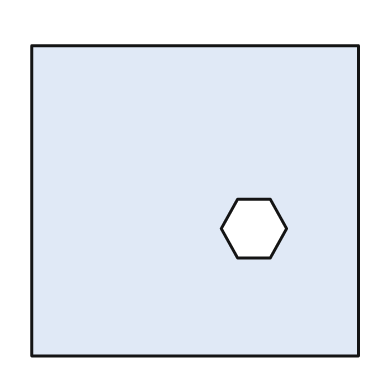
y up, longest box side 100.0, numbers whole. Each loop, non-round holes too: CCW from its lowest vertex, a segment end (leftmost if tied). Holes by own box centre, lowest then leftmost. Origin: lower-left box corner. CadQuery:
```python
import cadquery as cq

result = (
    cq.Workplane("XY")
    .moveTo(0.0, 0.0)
    .lineTo(100.0, 0.0)
    .lineTo(100.0, 95.0)
    .lineTo(0.0, 95.0)
    .close()
    .moveTo(63.0, 30.0)
    .lineTo(73.0, 30.0)
    .lineTo(78.0, 39.0)
    .lineTo(73.0, 48.0)
    .lineTo(63.0, 48.0)
    .lineTo(58.0, 39.0)
    .close()
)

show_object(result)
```